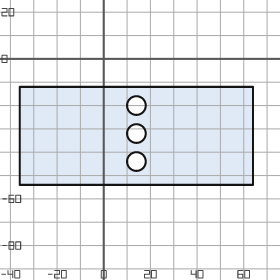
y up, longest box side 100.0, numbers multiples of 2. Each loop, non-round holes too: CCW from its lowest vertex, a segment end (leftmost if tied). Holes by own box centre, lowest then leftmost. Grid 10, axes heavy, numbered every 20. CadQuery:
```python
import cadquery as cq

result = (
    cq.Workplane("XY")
    .moveTo(-36.0, -54.0)
    .lineTo(64.0, -54.0)
    .lineTo(64.0, -12.0)
    .lineTo(-36.0, -12.0)
    .close()
    .moveTo(14.0, -44.0)
    .circle(4.0)
    .moveTo(14.0, -32.0)
    .circle(4.0)
    .moveTo(14.0, -20.0)
    .circle(4.0)
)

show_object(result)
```